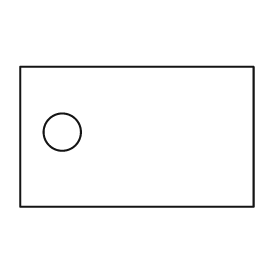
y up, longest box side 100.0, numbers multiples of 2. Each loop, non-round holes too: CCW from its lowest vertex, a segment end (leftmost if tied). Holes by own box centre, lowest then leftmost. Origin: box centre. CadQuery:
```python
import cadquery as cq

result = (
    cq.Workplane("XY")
    .moveTo(-50.0, -30.0)
    .lineTo(50.0, -30.0)
    .lineTo(50.0, 30.0)
    .lineTo(-50.0, 30.0)
    .close()
    .moveTo(-32.0, 2.0)
    .circle(8.0)
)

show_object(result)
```